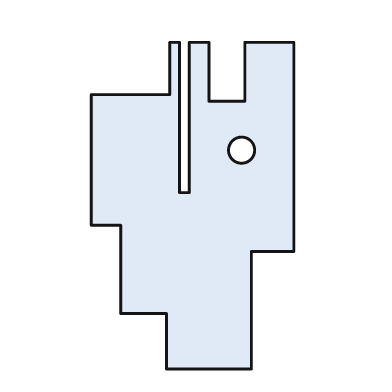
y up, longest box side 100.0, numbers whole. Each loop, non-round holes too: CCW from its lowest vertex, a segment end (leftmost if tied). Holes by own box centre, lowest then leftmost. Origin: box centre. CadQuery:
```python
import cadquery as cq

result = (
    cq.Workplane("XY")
    .moveTo(-8.0, -50.0)
    .lineTo(18.0, -50.0)
    .lineTo(18.0, -14.0)
    .lineTo(31.0, -14.0)
    .lineTo(31.0, 50.0)
    .lineTo(16.0, 50.0)
    .lineTo(16.0, 32.0)
    .lineTo(5.0, 32.0)
    .lineTo(5.0, 50.0)
    .lineTo(-1.0, 50.0)
    .lineTo(-1.0, 4.0)
    .lineTo(-4.0, 4.0)
    .lineTo(-4.0, 50.0)
    .lineTo(-7.0, 50.0)
    .lineTo(-7.0, 34.0)
    .lineTo(-31.0, 34.0)
    .lineTo(-31.0, -6.0)
    .lineTo(-22.0, -6.0)
    .lineTo(-22.0, -33.0)
    .lineTo(-8.0, -33.0)
    .close()
    .moveTo(15.0, 17.0)
    .circle(4.0)
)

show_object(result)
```